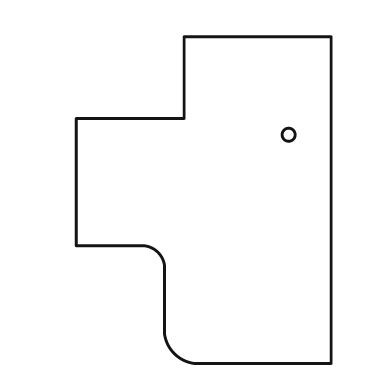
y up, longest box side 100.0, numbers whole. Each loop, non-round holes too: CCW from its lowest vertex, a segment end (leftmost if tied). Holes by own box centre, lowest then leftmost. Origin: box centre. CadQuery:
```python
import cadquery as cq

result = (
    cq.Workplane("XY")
    .moveTo(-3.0, -50.0)
    .lineTo(39.0, -50.0)
    .lineTo(39.0, 50.0)
    .lineTo(-6.0, 50.0)
    .lineTo(-6.0, 25.0)
    .lineTo(-39.0, 25.0)
    .lineTo(-39.0, -14.0)
    .lineTo(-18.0, -14.0)
    .threePointArc((-14.0, -16.0), (-12.0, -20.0))
    .lineTo(-12.0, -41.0)
    .threePointArc((-9.0, -47.0), (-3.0, -50.0))
    .close()
    .moveTo(26.0, 20.0)
    .circle(2.0)
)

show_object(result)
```